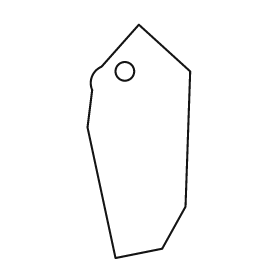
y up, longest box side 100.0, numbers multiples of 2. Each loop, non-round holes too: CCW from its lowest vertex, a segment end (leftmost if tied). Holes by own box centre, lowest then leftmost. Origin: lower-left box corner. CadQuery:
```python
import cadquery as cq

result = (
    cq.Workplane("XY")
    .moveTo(12.0, 0.0)
    .lineTo(32.0, 4.0)
    .lineTo(42.0, 22.0)
    .lineTo(44.0, 80.0)
    .lineTo(22.0, 100.0)
    .lineTo(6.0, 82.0)
    .threePointArc((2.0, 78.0), (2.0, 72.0))
    .lineTo(0.0, 56.0)
    .close()
    .moveTo(16.0, 80.0)
    .circle(4.0)
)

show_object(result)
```